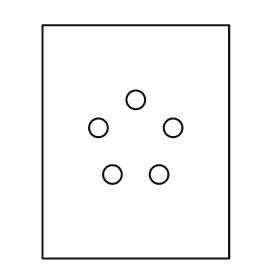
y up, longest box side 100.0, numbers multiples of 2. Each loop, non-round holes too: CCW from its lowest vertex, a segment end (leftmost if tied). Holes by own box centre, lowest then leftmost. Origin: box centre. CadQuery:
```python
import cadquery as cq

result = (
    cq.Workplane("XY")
    .moveTo(-40.0, -50.0)
    .lineTo(40.0, -50.0)
    .lineTo(40.0, 50.0)
    .lineTo(-40.0, 50.0)
    .close()
    .moveTo(-10.0, -14.0)
    .circle(4.0)
    .moveTo(10.0, -14.0)
    .circle(4.0)
    .moveTo(-16.0, 6.0)
    .circle(4.0)
    .moveTo(16.0, 6.0)
    .circle(4.0)
    .moveTo(0.0, 18.0)
    .circle(4.0)
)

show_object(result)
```